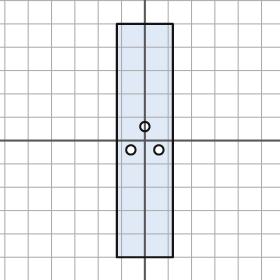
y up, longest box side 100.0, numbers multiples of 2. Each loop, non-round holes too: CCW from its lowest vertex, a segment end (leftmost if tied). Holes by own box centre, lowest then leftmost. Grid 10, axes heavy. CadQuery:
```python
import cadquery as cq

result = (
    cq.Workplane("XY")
    .moveTo(-12.0, -50.0)
    .lineTo(12.0, -50.0)
    .lineTo(12.0, 50.0)
    .lineTo(-12.0, 50.0)
    .close()
    .moveTo(-6.0, -4.0)
    .circle(2.0)
    .moveTo(6.0, -4.0)
    .circle(2.0)
    .moveTo(0.0, 6.0)
    .circle(2.0)
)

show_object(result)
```